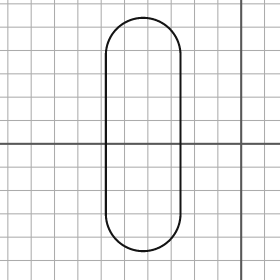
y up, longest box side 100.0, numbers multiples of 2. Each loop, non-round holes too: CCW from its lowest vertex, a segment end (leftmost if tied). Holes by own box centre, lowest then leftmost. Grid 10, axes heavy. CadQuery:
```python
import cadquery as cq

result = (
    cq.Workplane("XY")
    .moveTo(-58.0, -30.0)
    .threePointArc((-42.0, -46.0), (-26.0, -30.0))
    .lineTo(-26.0, 38.0)
    .threePointArc((-42.0, 54.0), (-58.0, 38.0))
    .close()
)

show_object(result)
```